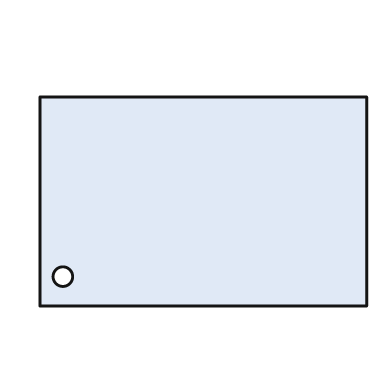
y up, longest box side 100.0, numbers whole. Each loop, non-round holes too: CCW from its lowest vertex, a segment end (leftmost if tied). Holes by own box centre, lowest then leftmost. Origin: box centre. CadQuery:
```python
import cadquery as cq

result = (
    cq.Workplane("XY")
    .moveTo(-50.0, -32.0)
    .lineTo(50.0, -32.0)
    .lineTo(50.0, 32.0)
    .lineTo(-50.0, 32.0)
    .close()
    .moveTo(-43.0, -23.0)
    .circle(3.0)
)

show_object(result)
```